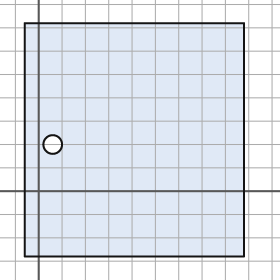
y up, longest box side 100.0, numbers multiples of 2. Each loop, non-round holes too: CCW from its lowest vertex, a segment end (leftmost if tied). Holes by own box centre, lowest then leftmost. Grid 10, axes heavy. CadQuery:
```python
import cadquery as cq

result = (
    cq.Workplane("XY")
    .moveTo(-6.0, -28.0)
    .lineTo(88.0, -28.0)
    .lineTo(88.0, 72.0)
    .lineTo(-6.0, 72.0)
    .close()
    .moveTo(6.0, 20.0)
    .circle(4.0)
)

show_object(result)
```